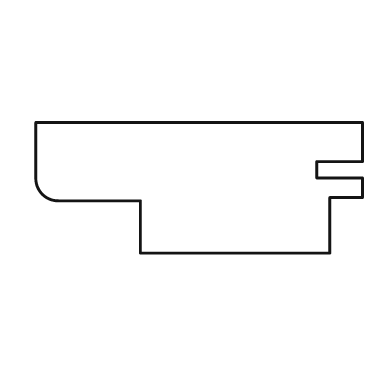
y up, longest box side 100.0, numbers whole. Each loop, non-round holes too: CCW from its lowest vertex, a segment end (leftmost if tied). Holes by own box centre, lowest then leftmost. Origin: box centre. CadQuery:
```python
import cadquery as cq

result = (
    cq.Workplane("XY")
    .moveTo(-18.0, -20.0)
    .lineTo(40.0, -20.0)
    .lineTo(40.0, -3.0)
    .lineTo(50.0, -3.0)
    .lineTo(50.0, 3.0)
    .lineTo(36.0, 3.0)
    .lineTo(36.0, 8.0)
    .lineTo(50.0, 8.0)
    .lineTo(50.0, 20.0)
    .lineTo(-50.0, 20.0)
    .lineTo(-50.0, 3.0)
    .threePointArc((-48.0, -2.0), (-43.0, -4.0))
    .lineTo(-18.0, -4.0)
    .close()
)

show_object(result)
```